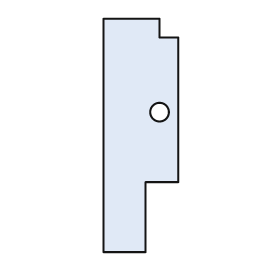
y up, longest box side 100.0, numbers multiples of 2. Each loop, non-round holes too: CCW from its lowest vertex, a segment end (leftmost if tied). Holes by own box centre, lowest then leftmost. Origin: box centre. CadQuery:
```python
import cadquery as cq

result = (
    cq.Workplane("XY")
    .moveTo(-16.0, -50.0)
    .lineTo(2.0, -50.0)
    .lineTo(2.0, -20.0)
    .lineTo(16.0, -20.0)
    .lineTo(16.0, 42.0)
    .lineTo(8.0, 42.0)
    .lineTo(8.0, 50.0)
    .lineTo(-16.0, 50.0)
    .close()
    .moveTo(8.0, 10.0)
    .circle(4.0)
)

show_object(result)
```